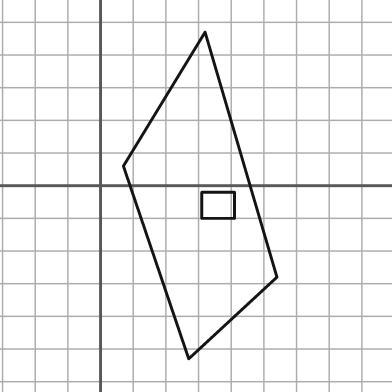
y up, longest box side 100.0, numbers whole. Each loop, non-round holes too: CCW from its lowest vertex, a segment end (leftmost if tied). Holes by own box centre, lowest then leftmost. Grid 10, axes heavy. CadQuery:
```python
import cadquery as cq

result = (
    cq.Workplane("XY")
    .moveTo(27.0, -53.0)
    .lineTo(54.0, -28.0)
    .lineTo(32.0, 47.0)
    .lineTo(7.0, 6.0)
    .close()
    .moveTo(31.0, -10.0)
    .lineTo(41.0, -10.0)
    .lineTo(41.0, -2.0)
    .lineTo(31.0, -2.0)
    .close()
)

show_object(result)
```